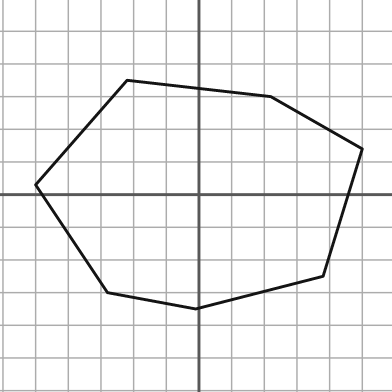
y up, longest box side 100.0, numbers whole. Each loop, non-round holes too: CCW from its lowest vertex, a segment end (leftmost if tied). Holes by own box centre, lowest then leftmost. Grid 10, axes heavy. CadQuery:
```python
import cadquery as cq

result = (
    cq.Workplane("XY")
    .moveTo(-1.0, -35.0)
    .lineTo(38.0, -25.0)
    .lineTo(50.0, 14.0)
    .lineTo(22.0, 30.0)
    .lineTo(-22.0, 35.0)
    .lineTo(-50.0, 3.0)
    .lineTo(-28.0, -30.0)
    .close()
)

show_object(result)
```